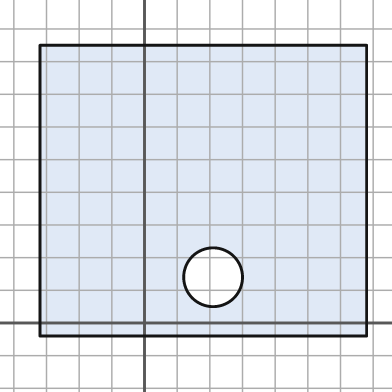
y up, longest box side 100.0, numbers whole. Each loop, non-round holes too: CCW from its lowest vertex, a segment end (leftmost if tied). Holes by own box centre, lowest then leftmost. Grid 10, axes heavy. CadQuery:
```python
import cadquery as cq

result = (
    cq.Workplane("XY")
    .moveTo(-32.0, -4.0)
    .lineTo(68.0, -4.0)
    .lineTo(68.0, 85.0)
    .lineTo(-32.0, 85.0)
    .close()
    .moveTo(21.0, 14.0)
    .circle(9.0)
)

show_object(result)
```